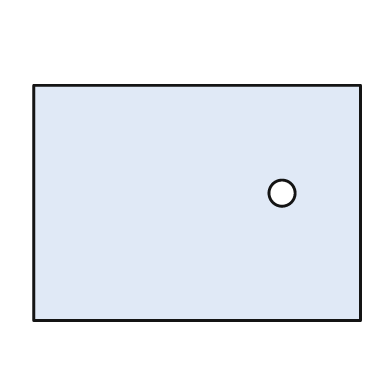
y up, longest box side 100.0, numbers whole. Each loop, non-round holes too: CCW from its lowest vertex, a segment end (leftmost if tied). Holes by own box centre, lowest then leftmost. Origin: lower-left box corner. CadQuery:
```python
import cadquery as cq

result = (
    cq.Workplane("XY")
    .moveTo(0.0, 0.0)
    .lineTo(100.0, 0.0)
    .lineTo(100.0, 72.0)
    .lineTo(0.0, 72.0)
    .close()
    .moveTo(76.0, 39.0)
    .circle(4.0)
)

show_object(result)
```